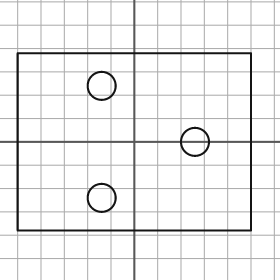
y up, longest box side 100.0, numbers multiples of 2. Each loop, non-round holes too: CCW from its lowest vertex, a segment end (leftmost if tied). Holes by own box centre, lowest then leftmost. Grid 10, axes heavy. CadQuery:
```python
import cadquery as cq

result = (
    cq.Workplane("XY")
    .moveTo(-50.0, -38.0)
    .lineTo(50.0, -38.0)
    .lineTo(50.0, 38.0)
    .lineTo(-50.0, 38.0)
    .close()
    .moveTo(-14.0, -24.0)
    .circle(6.0)
    .moveTo(26.0, 0.0)
    .circle(6.0)
    .moveTo(-14.0, 24.0)
    .circle(6.0)
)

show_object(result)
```